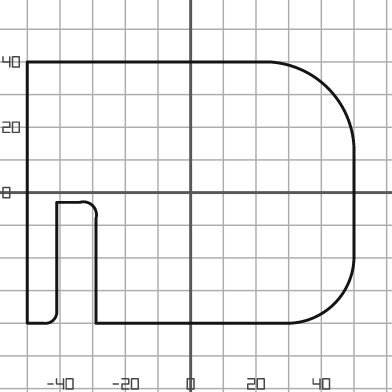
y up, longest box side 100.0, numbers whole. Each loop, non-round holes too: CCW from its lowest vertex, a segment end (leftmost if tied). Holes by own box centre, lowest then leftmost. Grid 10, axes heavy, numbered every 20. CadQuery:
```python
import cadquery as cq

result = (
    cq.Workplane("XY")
    .moveTo(-50.0, -40.0)
    .lineTo(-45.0, -40.0)
    .threePointArc((-42.0, -39.0), (-41.0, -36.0))
    .lineTo(-41.0, -3.0)
    .lineTo(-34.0, -3.0)
    .threePointArc((-30.0, -4.0), (-29.0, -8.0))
    .lineTo(-29.0, -40.0)
    .lineTo(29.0, -40.0)
    .threePointArc((44.0, -34.0), (50.0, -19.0))
    .lineTo(50.0, 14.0)
    .threePointArc((42.0, 32.0), (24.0, 40.0))
    .lineTo(-50.0, 40.0)
    .close()
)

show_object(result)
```